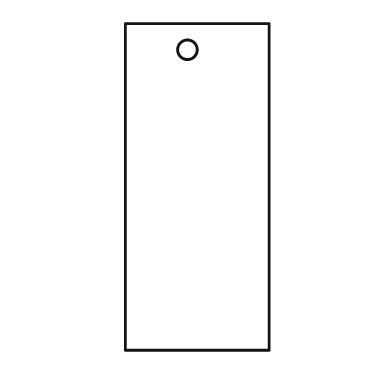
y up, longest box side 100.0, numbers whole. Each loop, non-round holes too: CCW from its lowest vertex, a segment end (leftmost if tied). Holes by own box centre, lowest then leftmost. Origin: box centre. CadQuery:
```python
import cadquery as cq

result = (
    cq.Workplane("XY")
    .moveTo(-22.0, -50.0)
    .lineTo(22.0, -50.0)
    .lineTo(22.0, 50.0)
    .lineTo(-22.0, 50.0)
    .close()
    .moveTo(-3.0, 42.0)
    .circle(3.0)
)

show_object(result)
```